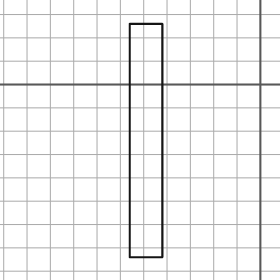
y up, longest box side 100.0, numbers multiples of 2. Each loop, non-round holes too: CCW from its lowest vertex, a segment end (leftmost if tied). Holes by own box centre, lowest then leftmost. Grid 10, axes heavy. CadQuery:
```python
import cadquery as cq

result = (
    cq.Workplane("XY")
    .moveTo(-56.0, -74.0)
    .lineTo(-42.0, -74.0)
    .lineTo(-42.0, 26.0)
    .lineTo(-56.0, 26.0)
    .close()
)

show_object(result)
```